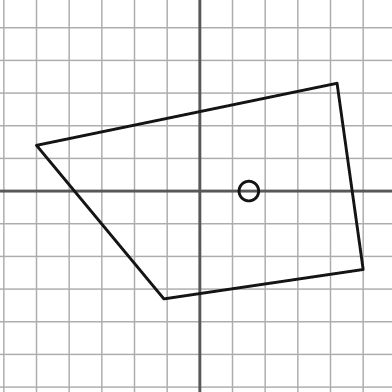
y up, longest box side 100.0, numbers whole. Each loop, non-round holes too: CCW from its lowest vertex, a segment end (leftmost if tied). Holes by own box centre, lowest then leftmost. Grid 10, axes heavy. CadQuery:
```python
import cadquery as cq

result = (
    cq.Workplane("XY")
    .moveTo(-11.0, -33.0)
    .lineTo(50.0, -24.0)
    .lineTo(42.0, 33.0)
    .lineTo(-50.0, 14.0)
    .close()
    .moveTo(15.0, 0.0)
    .circle(3.0)
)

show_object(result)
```